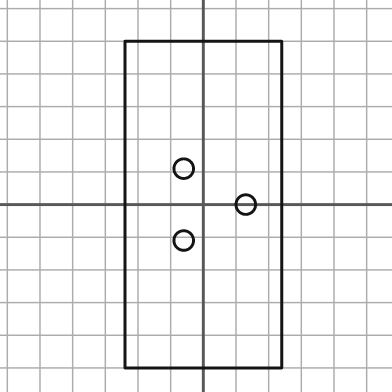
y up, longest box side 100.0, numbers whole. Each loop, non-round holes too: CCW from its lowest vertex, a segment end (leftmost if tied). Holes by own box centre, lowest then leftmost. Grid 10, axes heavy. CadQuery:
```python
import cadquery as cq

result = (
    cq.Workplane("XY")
    .moveTo(-24.0, -50.0)
    .lineTo(24.0, -50.0)
    .lineTo(24.0, 50.0)
    .lineTo(-24.0, 50.0)
    .close()
    .moveTo(-6.0, -11.0)
    .circle(3.0)
    .moveTo(13.0, 0.0)
    .circle(3.0)
    .moveTo(-6.0, 11.0)
    .circle(3.0)
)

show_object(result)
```